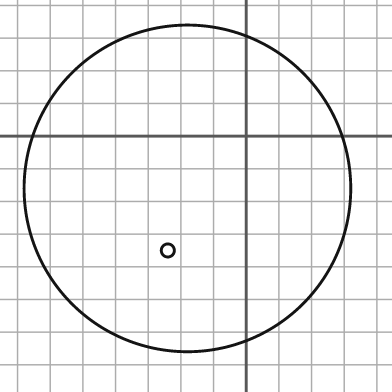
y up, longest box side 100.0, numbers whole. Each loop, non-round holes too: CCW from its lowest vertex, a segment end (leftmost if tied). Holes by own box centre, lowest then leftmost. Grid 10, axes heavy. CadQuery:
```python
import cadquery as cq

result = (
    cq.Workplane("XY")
    .moveTo(-18.0, -16.0)
    .circle(50.0)
    .moveTo(-24.0, -35.0)
    .circle(2.0)
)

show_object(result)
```